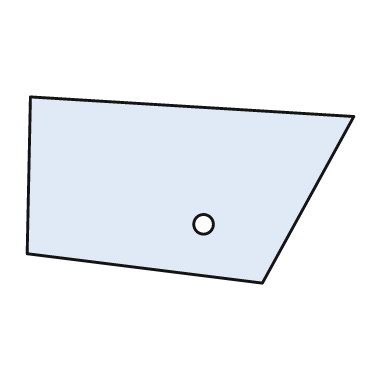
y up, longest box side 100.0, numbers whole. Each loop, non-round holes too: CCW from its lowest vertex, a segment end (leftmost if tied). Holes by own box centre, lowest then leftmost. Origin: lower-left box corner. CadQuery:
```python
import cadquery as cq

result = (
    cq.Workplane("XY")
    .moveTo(72.0, 0.0)
    .lineTo(100.0, 51.0)
    .lineTo(1.0, 57.0)
    .lineTo(0.0, 9.0)
    .close()
    .moveTo(54.0, 18.0)
    .circle(3.0)
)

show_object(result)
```